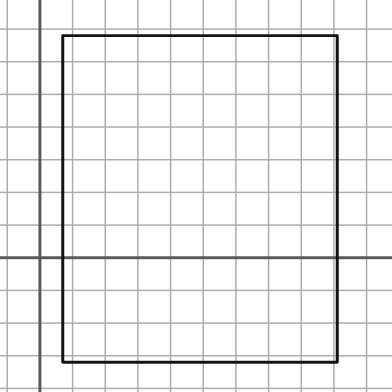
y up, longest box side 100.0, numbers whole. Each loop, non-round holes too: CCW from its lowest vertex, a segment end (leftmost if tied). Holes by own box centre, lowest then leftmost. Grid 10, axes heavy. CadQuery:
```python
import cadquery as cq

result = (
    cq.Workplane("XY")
    .moveTo(7.0, -32.0)
    .lineTo(91.0, -32.0)
    .lineTo(91.0, 68.0)
    .lineTo(7.0, 68.0)
    .close()
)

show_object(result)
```